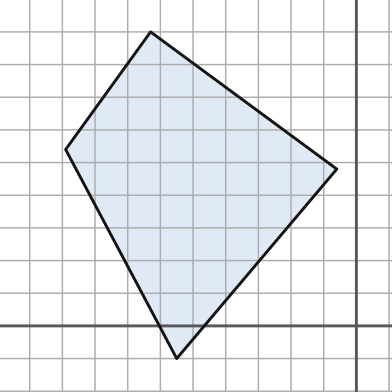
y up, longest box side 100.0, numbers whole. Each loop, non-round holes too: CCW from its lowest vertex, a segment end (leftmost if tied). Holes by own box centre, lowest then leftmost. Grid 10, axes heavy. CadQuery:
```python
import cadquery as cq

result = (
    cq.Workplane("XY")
    .moveTo(-55.0, -10.0)
    .lineTo(-6.0, 48.0)
    .lineTo(-63.0, 90.0)
    .lineTo(-89.0, 54.0)
    .close()
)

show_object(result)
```